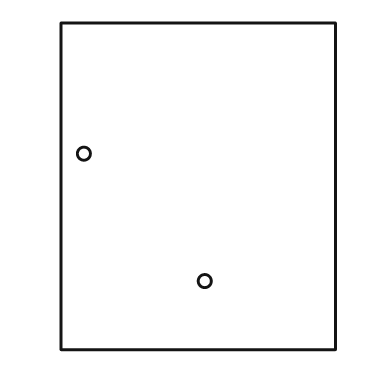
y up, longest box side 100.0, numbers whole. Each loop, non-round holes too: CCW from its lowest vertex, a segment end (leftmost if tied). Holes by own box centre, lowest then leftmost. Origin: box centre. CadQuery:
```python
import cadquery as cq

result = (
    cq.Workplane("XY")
    .moveTo(-42.0, -50.0)
    .lineTo(42.0, -50.0)
    .lineTo(42.0, 50.0)
    .lineTo(-42.0, 50.0)
    .close()
    .moveTo(2.0, -29.0)
    .circle(2.0)
    .moveTo(-35.0, 10.0)
    .circle(2.0)
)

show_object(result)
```